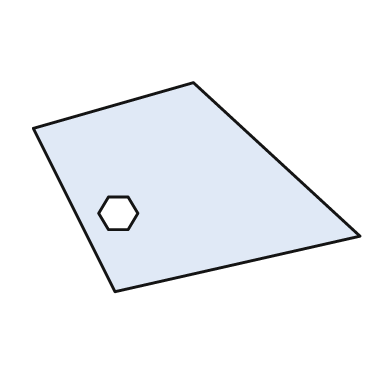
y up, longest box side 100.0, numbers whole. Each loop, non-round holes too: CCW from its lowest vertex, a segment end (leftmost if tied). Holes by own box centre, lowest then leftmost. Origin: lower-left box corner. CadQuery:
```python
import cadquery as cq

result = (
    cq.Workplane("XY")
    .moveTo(25.0, 0.0)
    .lineTo(100.0, 17.0)
    .lineTo(49.0, 64.0)
    .lineTo(0.0, 50.0)
    .close()
    .moveTo(23.0, 19.0)
    .lineTo(29.0, 19.0)
    .lineTo(32.0, 24.0)
    .lineTo(29.0, 29.0)
    .lineTo(23.0, 29.0)
    .lineTo(20.0, 24.0)
    .close()
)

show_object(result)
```